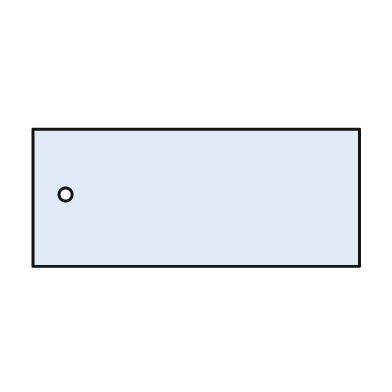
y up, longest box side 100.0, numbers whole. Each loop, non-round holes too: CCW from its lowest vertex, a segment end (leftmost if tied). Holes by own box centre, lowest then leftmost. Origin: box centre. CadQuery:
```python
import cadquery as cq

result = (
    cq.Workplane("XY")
    .moveTo(-50.0, -21.0)
    .lineTo(50.0, -21.0)
    .lineTo(50.0, 21.0)
    .lineTo(-50.0, 21.0)
    .close()
    .moveTo(-40.0, 1.0)
    .circle(2.0)
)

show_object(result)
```